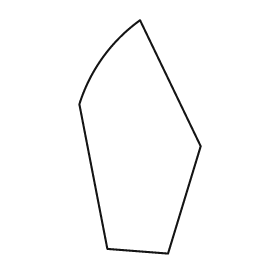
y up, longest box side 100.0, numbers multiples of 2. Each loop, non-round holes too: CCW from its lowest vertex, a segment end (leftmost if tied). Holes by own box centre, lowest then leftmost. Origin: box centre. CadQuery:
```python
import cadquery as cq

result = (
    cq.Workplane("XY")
    .moveTo(12.0, -50.0)
    .lineTo(26.0, -4.0)
    .lineTo(0.0, 50.0)
    .threePointArc((-16.0, 34.0), (-26.0, 14.0))
    .lineTo(-14.0, -48.0)
    .close()
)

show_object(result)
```